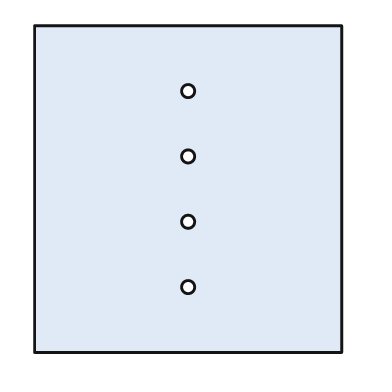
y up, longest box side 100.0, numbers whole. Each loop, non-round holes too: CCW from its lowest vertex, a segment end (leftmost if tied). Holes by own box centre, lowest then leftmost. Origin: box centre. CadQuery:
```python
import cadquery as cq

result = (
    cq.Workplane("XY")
    .moveTo(-47.0, -50.0)
    .lineTo(47.0, -50.0)
    .lineTo(47.0, 50.0)
    .lineTo(-47.0, 50.0)
    .close()
    .moveTo(0.0, -30.0)
    .circle(2.0)
    .moveTo(0.0, -10.0)
    .circle(2.0)
    .moveTo(0.0, 10.0)
    .circle(2.0)
    .moveTo(0.0, 30.0)
    .circle(2.0)
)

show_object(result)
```